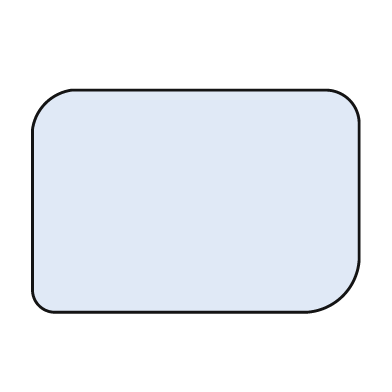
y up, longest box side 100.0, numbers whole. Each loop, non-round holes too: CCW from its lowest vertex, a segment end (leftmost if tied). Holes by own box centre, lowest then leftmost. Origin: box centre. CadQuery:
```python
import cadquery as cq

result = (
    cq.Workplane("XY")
    .moveTo(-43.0, -34.0)
    .lineTo(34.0, -34.0)
    .threePointArc((45.0, -29.0), (50.0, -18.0))
    .lineTo(50.0, 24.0)
    .threePointArc((47.0, 31.0), (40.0, 34.0))
    .lineTo(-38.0, 34.0)
    .threePointArc((-46.0, 30.0), (-50.0, 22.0))
    .lineTo(-50.0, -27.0)
    .threePointArc((-48.0, -32.0), (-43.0, -34.0))
    .close()
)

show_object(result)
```